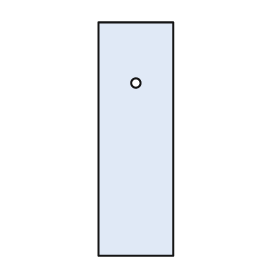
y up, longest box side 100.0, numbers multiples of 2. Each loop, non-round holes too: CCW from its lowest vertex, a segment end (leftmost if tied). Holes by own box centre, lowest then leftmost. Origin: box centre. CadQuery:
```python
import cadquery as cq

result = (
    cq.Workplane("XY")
    .moveTo(-16.0, -50.0)
    .lineTo(16.0, -50.0)
    .lineTo(16.0, 50.0)
    .lineTo(-16.0, 50.0)
    .close()
    .moveTo(0.0, 24.0)
    .circle(2.0)
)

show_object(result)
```